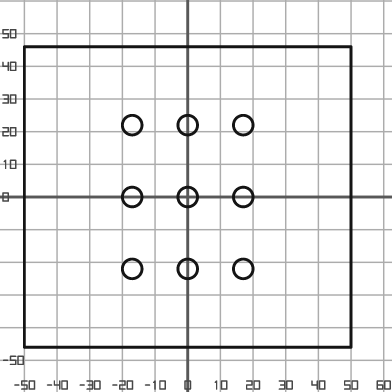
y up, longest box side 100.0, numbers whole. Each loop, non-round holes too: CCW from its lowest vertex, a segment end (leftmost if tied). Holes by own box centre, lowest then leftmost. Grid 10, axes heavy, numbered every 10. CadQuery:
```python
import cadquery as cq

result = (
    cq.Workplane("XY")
    .moveTo(-50.0, -46.0)
    .lineTo(50.0, -46.0)
    .lineTo(50.0, 46.0)
    .lineTo(-50.0, 46.0)
    .close()
    .moveTo(-17.0, -22.0)
    .circle(3.0)
    .moveTo(0.0, -22.0)
    .circle(3.0)
    .moveTo(17.0, -22.0)
    .circle(3.0)
    .moveTo(-17.0, 0.0)
    .circle(3.0)
    .moveTo(0.0, 0.0)
    .circle(3.0)
    .moveTo(17.0, 0.0)
    .circle(3.0)
    .moveTo(-17.0, 22.0)
    .circle(3.0)
    .moveTo(0.0, 22.0)
    .circle(3.0)
    .moveTo(17.0, 22.0)
    .circle(3.0)
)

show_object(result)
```